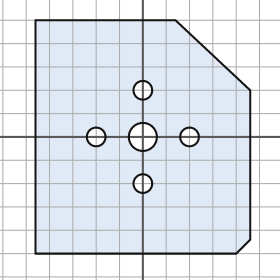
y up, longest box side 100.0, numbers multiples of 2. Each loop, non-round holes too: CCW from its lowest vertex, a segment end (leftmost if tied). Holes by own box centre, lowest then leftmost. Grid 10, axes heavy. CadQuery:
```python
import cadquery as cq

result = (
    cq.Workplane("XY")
    .moveTo(-46.0, -50.0)
    .lineTo(40.0, -50.0)
    .lineTo(46.0, -44.0)
    .lineTo(46.0, 20.0)
    .lineTo(14.0, 50.0)
    .lineTo(-46.0, 50.0)
    .close()
    .moveTo(0.0, -20.0)
    .circle(4.0)
    .moveTo(-20.0, 0.0)
    .circle(4.0)
    .moveTo(0.0, 0.0)
    .circle(6.0)
    .moveTo(20.0, 0.0)
    .circle(4.0)
    .moveTo(0.0, 20.0)
    .circle(4.0)
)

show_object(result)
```